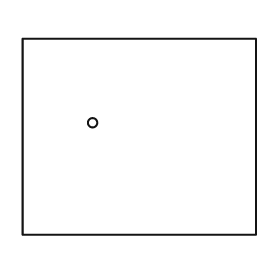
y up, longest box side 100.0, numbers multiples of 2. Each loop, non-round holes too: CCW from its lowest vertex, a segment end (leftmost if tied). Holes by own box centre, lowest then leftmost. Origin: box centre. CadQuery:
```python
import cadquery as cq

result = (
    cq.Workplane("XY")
    .moveTo(-50.0, -42.0)
    .lineTo(50.0, -42.0)
    .lineTo(50.0, 42.0)
    .lineTo(-50.0, 42.0)
    .close()
    .moveTo(-20.0, 6.0)
    .circle(2.0)
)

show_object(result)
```